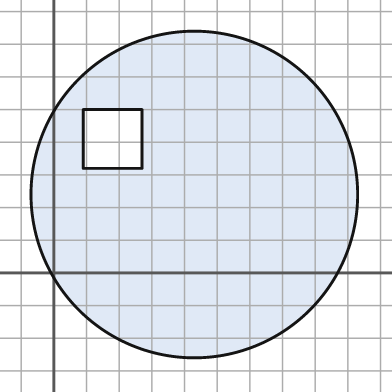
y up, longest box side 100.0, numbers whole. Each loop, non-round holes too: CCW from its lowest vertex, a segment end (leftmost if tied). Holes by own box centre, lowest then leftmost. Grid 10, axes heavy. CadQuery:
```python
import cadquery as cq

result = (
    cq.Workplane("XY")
    .moveTo(43.0, 24.0)
    .circle(50.0)
    .moveTo(9.0, 32.0)
    .lineTo(27.0, 32.0)
    .lineTo(27.0, 50.0)
    .lineTo(9.0, 50.0)
    .close()
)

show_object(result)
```